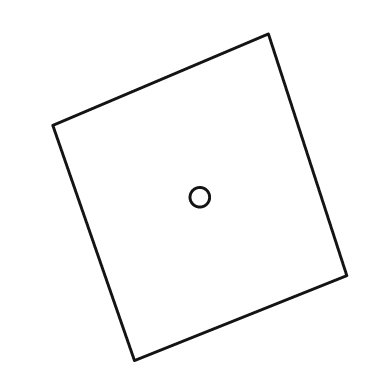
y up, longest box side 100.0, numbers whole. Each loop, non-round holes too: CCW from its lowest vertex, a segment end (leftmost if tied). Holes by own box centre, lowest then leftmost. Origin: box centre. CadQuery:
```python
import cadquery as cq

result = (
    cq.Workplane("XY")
    .moveTo(-20.0, -50.0)
    .lineTo(45.0, -24.0)
    .lineTo(21.0, 50.0)
    .lineTo(-45.0, 22.0)
    .close()
    .moveTo(0.0, 0.0)
    .circle(3.0)
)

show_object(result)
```